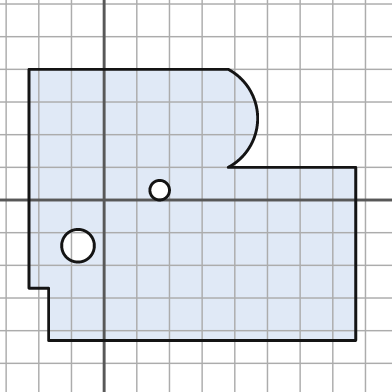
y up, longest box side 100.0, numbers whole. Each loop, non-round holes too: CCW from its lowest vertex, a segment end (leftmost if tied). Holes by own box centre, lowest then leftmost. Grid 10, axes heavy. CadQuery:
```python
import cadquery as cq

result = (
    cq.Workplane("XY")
    .moveTo(-17.0, -43.0)
    .lineTo(77.0, -43.0)
    .lineTo(77.0, 10.0)
    .lineTo(38.0, 10.0)
    .threePointArc((47.0, 25.0), (38.0, 40.0))
    .lineTo(-23.0, 40.0)
    .lineTo(-23.0, -27.0)
    .lineTo(-17.0, -27.0)
    .close()
    .moveTo(-8.0, -14.0)
    .circle(5.0)
    .moveTo(17.0, 3.0)
    .circle(3.0)
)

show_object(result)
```